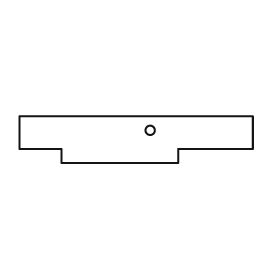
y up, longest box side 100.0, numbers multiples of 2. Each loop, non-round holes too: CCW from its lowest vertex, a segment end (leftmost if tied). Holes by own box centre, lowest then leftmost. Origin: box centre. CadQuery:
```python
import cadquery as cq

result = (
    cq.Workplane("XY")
    .moveTo(-32.0, -10.0)
    .lineTo(18.0, -10.0)
    .lineTo(18.0, -4.0)
    .lineTo(50.0, -4.0)
    .lineTo(50.0, 10.0)
    .lineTo(-50.0, 10.0)
    .lineTo(-50.0, -4.0)
    .lineTo(-32.0, -4.0)
    .close()
    .moveTo(6.0, 4.0)
    .circle(2.0)
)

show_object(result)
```